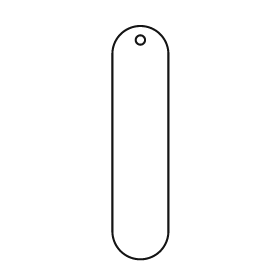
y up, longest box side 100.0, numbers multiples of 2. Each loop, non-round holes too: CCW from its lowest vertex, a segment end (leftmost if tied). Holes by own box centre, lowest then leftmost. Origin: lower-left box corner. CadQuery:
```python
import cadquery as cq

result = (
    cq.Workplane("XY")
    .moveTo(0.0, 12.0)
    .threePointArc((12.0, 0.0), (24.0, 12.0))
    .lineTo(24.0, 88.0)
    .threePointArc((12.0, 100.0), (0.0, 88.0))
    .close()
    .moveTo(12.0, 94.0)
    .circle(2.0)
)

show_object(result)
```